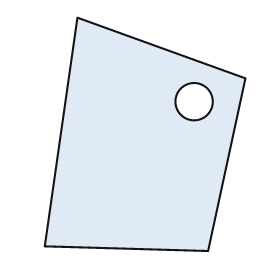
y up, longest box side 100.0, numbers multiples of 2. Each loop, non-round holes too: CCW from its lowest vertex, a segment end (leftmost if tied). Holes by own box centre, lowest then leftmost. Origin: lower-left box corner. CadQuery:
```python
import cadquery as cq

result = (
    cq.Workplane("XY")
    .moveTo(70.0, 0.0)
    .lineTo(86.0, 74.0)
    .lineTo(14.0, 100.0)
    .lineTo(0.0, 2.0)
    .close()
    .moveTo(64.0, 64.0)
    .circle(8.0)
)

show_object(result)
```